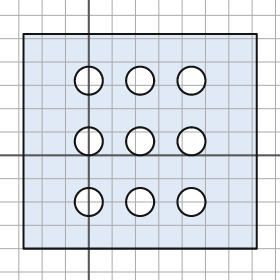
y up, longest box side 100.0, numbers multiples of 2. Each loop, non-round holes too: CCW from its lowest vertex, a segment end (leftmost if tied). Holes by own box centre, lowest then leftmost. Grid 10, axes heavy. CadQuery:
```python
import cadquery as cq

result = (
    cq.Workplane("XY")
    .moveTo(-28.0, -40.0)
    .lineTo(72.0, -40.0)
    .lineTo(72.0, 52.0)
    .lineTo(-28.0, 52.0)
    .close()
    .moveTo(0.0, -20.0)
    .circle(6.0)
    .moveTo(22.0, -20.0)
    .circle(6.0)
    .moveTo(44.0, -20.0)
    .circle(6.0)
    .moveTo(0.0, 6.0)
    .circle(6.0)
    .moveTo(22.0, 6.0)
    .circle(6.0)
    .moveTo(44.0, 6.0)
    .circle(6.0)
    .moveTo(0.0, 32.0)
    .circle(6.0)
    .moveTo(22.0, 32.0)
    .circle(6.0)
    .moveTo(44.0, 32.0)
    .circle(6.0)
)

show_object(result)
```